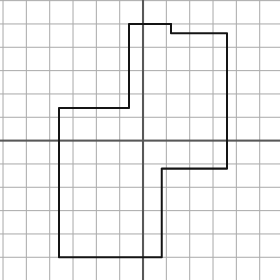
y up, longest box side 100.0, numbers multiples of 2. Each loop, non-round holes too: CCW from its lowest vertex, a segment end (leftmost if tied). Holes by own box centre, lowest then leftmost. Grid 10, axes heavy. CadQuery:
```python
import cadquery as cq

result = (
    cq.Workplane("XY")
    .moveTo(-36.0, -50.0)
    .lineTo(8.0, -50.0)
    .lineTo(8.0, -12.0)
    .lineTo(36.0, -12.0)
    .lineTo(36.0, 46.0)
    .lineTo(12.0, 46.0)
    .lineTo(12.0, 50.0)
    .lineTo(-6.0, 50.0)
    .lineTo(-6.0, 14.0)
    .lineTo(-36.0, 14.0)
    .close()
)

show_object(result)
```